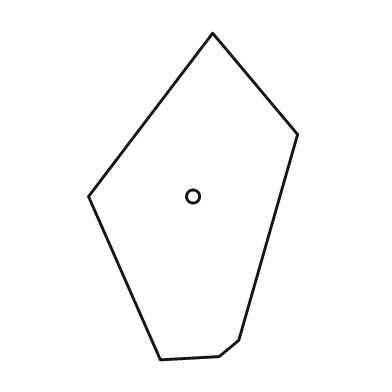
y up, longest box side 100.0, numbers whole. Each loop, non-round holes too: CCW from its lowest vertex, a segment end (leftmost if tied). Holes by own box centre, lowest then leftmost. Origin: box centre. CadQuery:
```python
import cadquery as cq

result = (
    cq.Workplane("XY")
    .moveTo(-10.0, -50.0)
    .lineTo(8.0, -49.0)
    .lineTo(14.0, -44.0)
    .lineTo(32.0, 19.0)
    .lineTo(6.0, 50.0)
    .lineTo(-32.0, 0.0)
    .close()
    .moveTo(0.0, 0.0)
    .circle(2.0)
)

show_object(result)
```